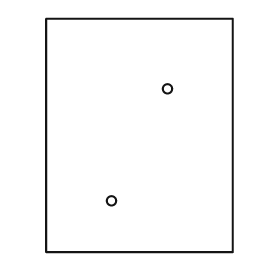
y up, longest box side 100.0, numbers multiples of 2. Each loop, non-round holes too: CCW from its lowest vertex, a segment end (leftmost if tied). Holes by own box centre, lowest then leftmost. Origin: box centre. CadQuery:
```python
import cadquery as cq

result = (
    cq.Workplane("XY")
    .moveTo(-40.0, -50.0)
    .lineTo(40.0, -50.0)
    .lineTo(40.0, 50.0)
    .lineTo(-40.0, 50.0)
    .close()
    .moveTo(-12.0, -28.0)
    .circle(2.0)
    .moveTo(12.0, 20.0)
    .circle(2.0)
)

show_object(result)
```